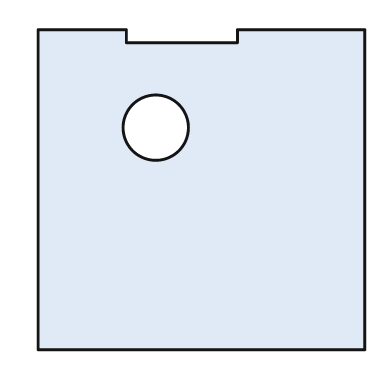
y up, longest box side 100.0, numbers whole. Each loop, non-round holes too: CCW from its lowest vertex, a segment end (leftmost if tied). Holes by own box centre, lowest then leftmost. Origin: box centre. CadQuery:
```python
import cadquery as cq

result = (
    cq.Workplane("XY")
    .moveTo(-50.0, -49.0)
    .lineTo(50.0, -49.0)
    .lineTo(50.0, 49.0)
    .lineTo(11.0, 49.0)
    .lineTo(11.0, 45.0)
    .lineTo(-23.0, 45.0)
    .lineTo(-23.0, 49.0)
    .lineTo(-50.0, 49.0)
    .close()
    .moveTo(-14.0, 19.0)
    .circle(10.0)
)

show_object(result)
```